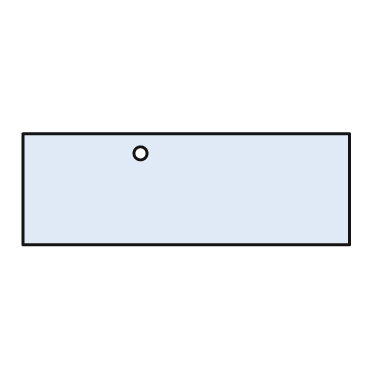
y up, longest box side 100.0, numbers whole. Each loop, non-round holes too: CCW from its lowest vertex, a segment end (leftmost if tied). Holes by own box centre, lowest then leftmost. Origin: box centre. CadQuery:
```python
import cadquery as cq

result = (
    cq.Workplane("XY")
    .moveTo(-50.0, -17.0)
    .lineTo(50.0, -17.0)
    .lineTo(50.0, 17.0)
    .lineTo(-50.0, 17.0)
    .close()
    .moveTo(-14.0, 11.0)
    .circle(2.0)
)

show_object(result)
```